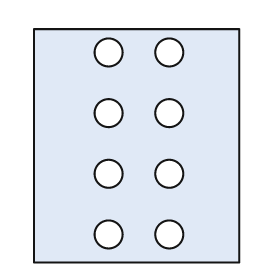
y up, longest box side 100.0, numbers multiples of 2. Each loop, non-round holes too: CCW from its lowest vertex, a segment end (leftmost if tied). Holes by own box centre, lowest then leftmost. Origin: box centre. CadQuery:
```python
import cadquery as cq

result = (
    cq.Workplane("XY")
    .moveTo(-44.0, -50.0)
    .lineTo(44.0, -50.0)
    .lineTo(44.0, 50.0)
    .lineTo(-44.0, 50.0)
    .close()
    .moveTo(-12.0, -38.0)
    .circle(6.0)
    .moveTo(14.0, -38.0)
    .circle(6.0)
    .moveTo(-12.0, -12.0)
    .circle(6.0)
    .moveTo(14.0, -12.0)
    .circle(6.0)
    .moveTo(-12.0, 14.0)
    .circle(6.0)
    .moveTo(14.0, 14.0)
    .circle(6.0)
    .moveTo(-12.0, 40.0)
    .circle(6.0)
    .moveTo(14.0, 40.0)
    .circle(6.0)
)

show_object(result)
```